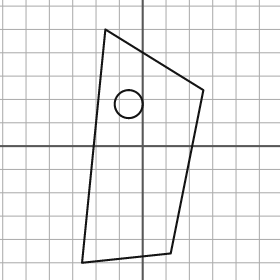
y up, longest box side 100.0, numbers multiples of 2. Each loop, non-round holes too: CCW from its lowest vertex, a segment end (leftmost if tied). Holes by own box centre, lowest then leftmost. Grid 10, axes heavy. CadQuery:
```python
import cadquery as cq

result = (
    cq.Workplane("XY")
    .moveTo(-26.0, -50.0)
    .lineTo(12.0, -46.0)
    .lineTo(26.0, 24.0)
    .lineTo(-16.0, 50.0)
    .close()
    .moveTo(-6.0, 18.0)
    .circle(6.0)
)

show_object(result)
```